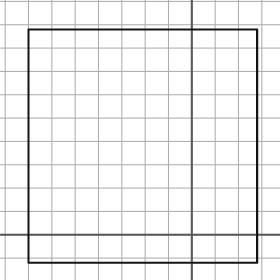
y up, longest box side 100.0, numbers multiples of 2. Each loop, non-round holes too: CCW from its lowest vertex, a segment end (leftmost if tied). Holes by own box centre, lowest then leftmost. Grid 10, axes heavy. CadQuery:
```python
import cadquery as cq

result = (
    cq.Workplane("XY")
    .moveTo(-70.0, -12.0)
    .lineTo(28.0, -12.0)
    .lineTo(28.0, 88.0)
    .lineTo(-70.0, 88.0)
    .close()
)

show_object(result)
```